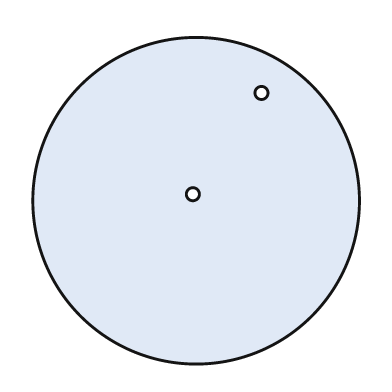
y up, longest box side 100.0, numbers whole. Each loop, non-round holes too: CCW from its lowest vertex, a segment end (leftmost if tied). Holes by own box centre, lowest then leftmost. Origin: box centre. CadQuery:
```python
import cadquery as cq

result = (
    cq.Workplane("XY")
    .moveTo(0.0, 0.0)
    .circle(50.0)
    .moveTo(-1.0, 2.0)
    .circle(2.0)
    .moveTo(20.0, 33.0)
    .circle(2.0)
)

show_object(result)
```